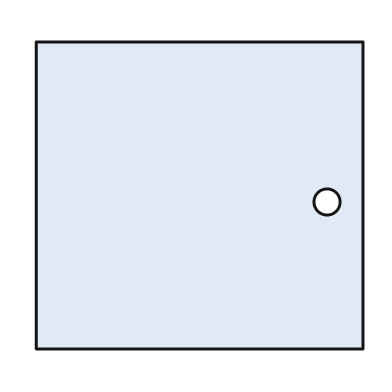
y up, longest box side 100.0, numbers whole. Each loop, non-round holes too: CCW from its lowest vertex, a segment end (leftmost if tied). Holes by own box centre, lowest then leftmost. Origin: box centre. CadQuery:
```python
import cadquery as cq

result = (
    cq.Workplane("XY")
    .moveTo(-50.0, -47.0)
    .lineTo(50.0, -47.0)
    .lineTo(50.0, 47.0)
    .lineTo(-50.0, 47.0)
    .close()
    .moveTo(39.0, -2.0)
    .circle(4.0)
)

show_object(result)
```